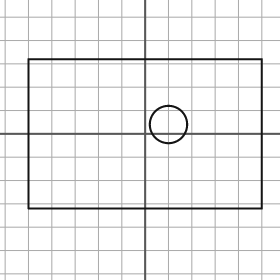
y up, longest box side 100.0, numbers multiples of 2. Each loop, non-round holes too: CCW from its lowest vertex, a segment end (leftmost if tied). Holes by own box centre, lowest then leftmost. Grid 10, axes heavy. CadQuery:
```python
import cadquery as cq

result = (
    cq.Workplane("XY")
    .moveTo(-50.0, -32.0)
    .lineTo(50.0, -32.0)
    .lineTo(50.0, 32.0)
    .lineTo(-50.0, 32.0)
    .close()
    .moveTo(10.0, 4.0)
    .circle(8.0)
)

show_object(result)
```